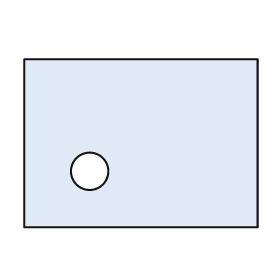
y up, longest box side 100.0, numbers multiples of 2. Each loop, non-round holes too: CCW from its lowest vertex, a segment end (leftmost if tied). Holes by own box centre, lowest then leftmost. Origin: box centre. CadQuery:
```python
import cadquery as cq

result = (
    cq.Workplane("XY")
    .moveTo(-50.0, -36.0)
    .lineTo(50.0, -36.0)
    .lineTo(50.0, 36.0)
    .lineTo(-50.0, 36.0)
    .close()
    .moveTo(-22.0, -12.0)
    .circle(8.0)
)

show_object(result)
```